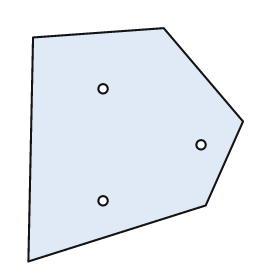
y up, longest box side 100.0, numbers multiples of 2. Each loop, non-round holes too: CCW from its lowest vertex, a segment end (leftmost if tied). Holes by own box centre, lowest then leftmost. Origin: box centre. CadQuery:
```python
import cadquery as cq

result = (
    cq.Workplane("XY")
    .moveTo(-46.0, -50.0)
    .lineTo(30.0, -26.0)
    .lineTo(46.0, 10.0)
    .lineTo(12.0, 50.0)
    .lineTo(-44.0, 46.0)
    .close()
    .moveTo(-14.0, -24.0)
    .circle(2.0)
    .moveTo(28.0, 0.0)
    .circle(2.0)
    .moveTo(-14.0, 24.0)
    .circle(2.0)
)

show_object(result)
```